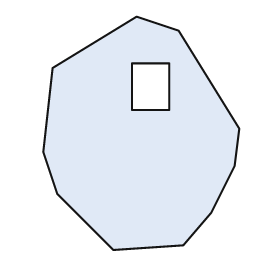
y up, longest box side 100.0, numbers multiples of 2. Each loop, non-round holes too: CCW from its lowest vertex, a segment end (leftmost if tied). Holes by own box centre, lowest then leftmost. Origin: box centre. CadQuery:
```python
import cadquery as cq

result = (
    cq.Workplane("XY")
    .moveTo(-12.0, -50.0)
    .lineTo(18.0, -48.0)
    .lineTo(30.0, -34.0)
    .lineTo(40.0, -14.0)
    .lineTo(42.0, 2.0)
    .lineTo(16.0, 44.0)
    .lineTo(-2.0, 50.0)
    .lineTo(-38.0, 28.0)
    .lineTo(-42.0, -8.0)
    .lineTo(-36.0, -26.0)
    .close()
    .moveTo(-4.0, 10.0)
    .lineTo(12.0, 10.0)
    .lineTo(12.0, 30.0)
    .lineTo(-4.0, 30.0)
    .close()
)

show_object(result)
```